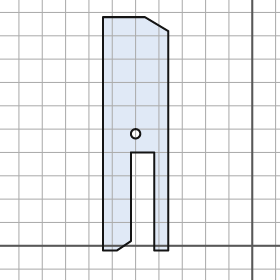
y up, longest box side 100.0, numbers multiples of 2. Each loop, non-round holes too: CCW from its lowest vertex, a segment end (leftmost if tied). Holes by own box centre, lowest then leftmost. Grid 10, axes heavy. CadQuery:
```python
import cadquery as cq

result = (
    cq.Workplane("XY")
    .moveTo(-64.0, -2.0)
    .lineTo(-58.0, -2.0)
    .lineTo(-52.0, 2.0)
    .lineTo(-52.0, 40.0)
    .lineTo(-42.0, 40.0)
    .lineTo(-42.0, -2.0)
    .lineTo(-36.0, -2.0)
    .lineTo(-36.0, 92.0)
    .lineTo(-46.0, 98.0)
    .lineTo(-64.0, 98.0)
    .close()
    .moveTo(-50.0, 48.0)
    .circle(2.0)
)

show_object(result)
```